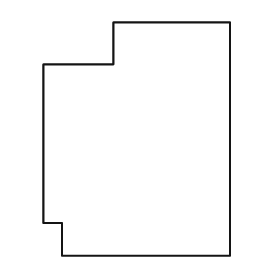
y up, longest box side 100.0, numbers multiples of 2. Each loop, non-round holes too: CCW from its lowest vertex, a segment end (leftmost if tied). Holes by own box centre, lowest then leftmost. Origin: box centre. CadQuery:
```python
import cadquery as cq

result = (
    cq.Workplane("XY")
    .moveTo(-32.0, -50.0)
    .lineTo(40.0, -50.0)
    .lineTo(40.0, 50.0)
    .lineTo(-10.0, 50.0)
    .lineTo(-10.0, 32.0)
    .lineTo(-40.0, 32.0)
    .lineTo(-40.0, -36.0)
    .lineTo(-32.0, -36.0)
    .close()
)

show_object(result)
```